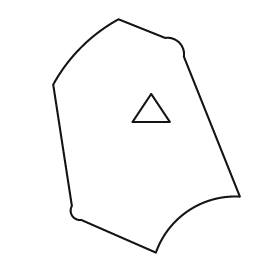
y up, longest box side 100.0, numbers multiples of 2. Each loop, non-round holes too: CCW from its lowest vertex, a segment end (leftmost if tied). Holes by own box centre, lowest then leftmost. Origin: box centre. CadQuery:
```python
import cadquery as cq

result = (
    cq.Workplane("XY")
    .moveTo(4.0, -50.0)
    .threePointArc((18.0, -32.0), (40.0, -26.0))
    .lineTo(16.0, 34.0)
    .threePointArc((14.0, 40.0), (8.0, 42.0))
    .lineTo(-12.0, 50.0)
    .threePointArc((-28.0, 38.0), (-40.0, 22.0))
    .lineTo(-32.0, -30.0)
    .threePointArc((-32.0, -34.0), (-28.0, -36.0))
    .close()
    .moveTo(-6.0, 6.0)
    .lineTo(10.0, 6.0)
    .lineTo(2.0, 18.0)
    .close()
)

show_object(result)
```